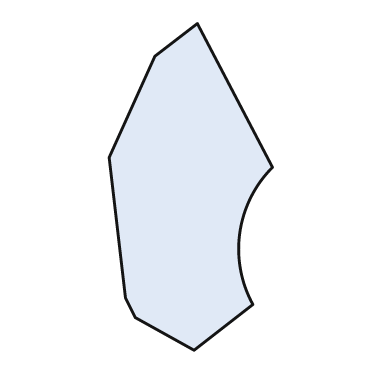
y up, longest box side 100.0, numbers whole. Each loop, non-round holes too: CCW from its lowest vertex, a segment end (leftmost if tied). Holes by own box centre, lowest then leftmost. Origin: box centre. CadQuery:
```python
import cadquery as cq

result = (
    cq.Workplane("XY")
    .moveTo(1.0, -50.0)
    .lineTo(19.0, -36.0)
    .threePointArc((15.0, -14.0), (25.0, 6.0))
    .lineTo(2.0, 50.0)
    .lineTo(-11.0, 40.0)
    .lineTo(-25.0, 9.0)
    .lineTo(-20.0, -34.0)
    .lineTo(-17.0, -40.0)
    .close()
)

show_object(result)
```